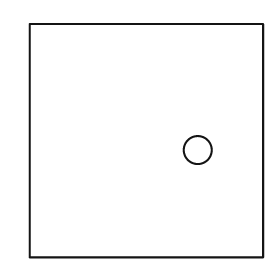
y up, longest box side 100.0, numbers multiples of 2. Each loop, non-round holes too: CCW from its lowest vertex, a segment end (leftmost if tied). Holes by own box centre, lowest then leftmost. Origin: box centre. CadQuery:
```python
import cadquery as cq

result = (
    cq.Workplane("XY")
    .moveTo(-50.0, -50.0)
    .lineTo(50.0, -50.0)
    .lineTo(50.0, 50.0)
    .lineTo(-50.0, 50.0)
    .close()
    .moveTo(22.0, -4.0)
    .circle(6.0)
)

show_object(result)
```